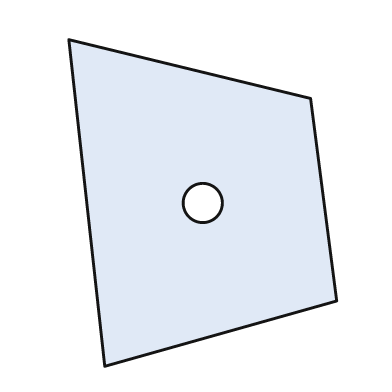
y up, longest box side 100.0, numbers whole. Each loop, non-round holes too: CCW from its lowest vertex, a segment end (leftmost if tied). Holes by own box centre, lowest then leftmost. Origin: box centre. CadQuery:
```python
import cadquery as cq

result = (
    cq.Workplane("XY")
    .moveTo(-30.0, -50.0)
    .lineTo(41.0, -30.0)
    .lineTo(33.0, 32.0)
    .lineTo(-41.0, 50.0)
    .close()
    .moveTo(0.0, 0.0)
    .circle(6.0)
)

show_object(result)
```